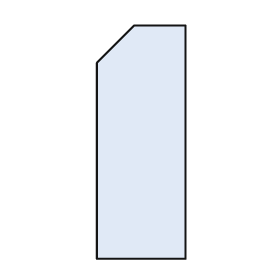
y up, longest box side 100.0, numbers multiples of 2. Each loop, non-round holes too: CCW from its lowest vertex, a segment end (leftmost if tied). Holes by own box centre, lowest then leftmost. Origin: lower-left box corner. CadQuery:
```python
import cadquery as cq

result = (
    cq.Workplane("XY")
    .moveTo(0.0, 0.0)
    .lineTo(38.0, 0.0)
    .lineTo(38.0, 100.0)
    .lineTo(16.0, 100.0)
    .lineTo(0.0, 84.0)
    .close()
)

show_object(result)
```